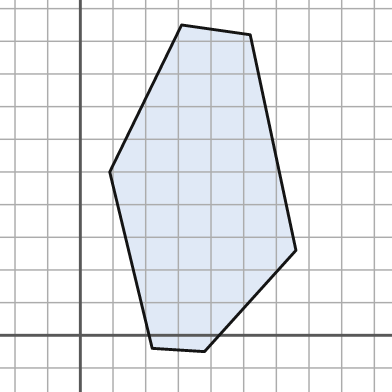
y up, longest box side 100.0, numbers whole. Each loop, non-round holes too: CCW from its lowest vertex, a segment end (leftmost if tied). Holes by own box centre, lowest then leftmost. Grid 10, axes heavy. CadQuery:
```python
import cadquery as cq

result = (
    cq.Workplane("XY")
    .moveTo(38.0, -5.0)
    .lineTo(66.0, 26.0)
    .lineTo(52.0, 92.0)
    .lineTo(31.0, 95.0)
    .lineTo(9.0, 50.0)
    .lineTo(22.0, -4.0)
    .close()
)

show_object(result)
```